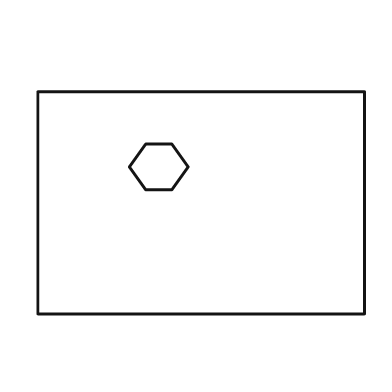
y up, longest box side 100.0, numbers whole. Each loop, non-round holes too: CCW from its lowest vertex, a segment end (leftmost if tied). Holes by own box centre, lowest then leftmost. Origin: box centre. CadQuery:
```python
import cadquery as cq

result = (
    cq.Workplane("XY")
    .moveTo(-50.0, -34.0)
    .lineTo(50.0, -34.0)
    .lineTo(50.0, 34.0)
    .lineTo(-50.0, 34.0)
    .close()
    .moveTo(-17.0, 4.0)
    .lineTo(-9.0, 4.0)
    .lineTo(-4.0, 11.0)
    .lineTo(-9.0, 18.0)
    .lineTo(-17.0, 18.0)
    .lineTo(-22.0, 11.0)
    .close()
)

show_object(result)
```